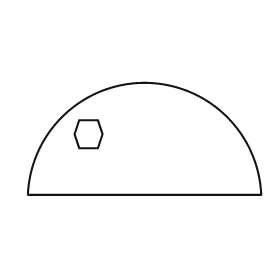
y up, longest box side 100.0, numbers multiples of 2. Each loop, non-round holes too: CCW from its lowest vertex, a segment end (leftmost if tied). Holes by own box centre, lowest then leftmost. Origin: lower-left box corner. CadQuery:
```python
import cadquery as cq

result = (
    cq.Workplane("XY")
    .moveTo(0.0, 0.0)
    .lineTo(100.0, 0.0)
    .threePointArc((50.0, 48.0), (0.0, 0.0))
    .close()
    .moveTo(22.0, 20.0)
    .lineTo(30.0, 20.0)
    .lineTo(32.0, 26.0)
    .lineTo(30.0, 32.0)
    .lineTo(22.0, 32.0)
    .lineTo(20.0, 26.0)
    .close()
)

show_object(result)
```